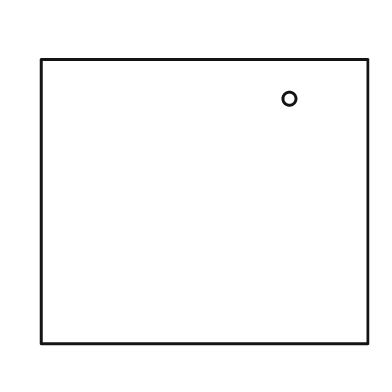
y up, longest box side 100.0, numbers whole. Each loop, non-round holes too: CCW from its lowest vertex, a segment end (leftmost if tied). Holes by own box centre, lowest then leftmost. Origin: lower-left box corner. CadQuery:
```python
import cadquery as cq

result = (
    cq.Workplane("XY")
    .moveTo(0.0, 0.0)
    .lineTo(100.0, 0.0)
    .lineTo(100.0, 87.0)
    .lineTo(0.0, 87.0)
    .close()
    .moveTo(76.0, 75.0)
    .circle(2.0)
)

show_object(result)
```